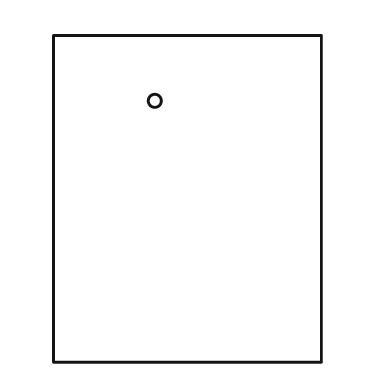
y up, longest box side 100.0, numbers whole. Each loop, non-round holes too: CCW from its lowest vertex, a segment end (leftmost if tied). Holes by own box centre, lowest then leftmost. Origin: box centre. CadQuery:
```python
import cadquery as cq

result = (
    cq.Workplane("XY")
    .moveTo(-41.0, -50.0)
    .lineTo(41.0, -50.0)
    .lineTo(41.0, 50.0)
    .lineTo(-41.0, 50.0)
    .close()
    .moveTo(-10.0, 30.0)
    .circle(2.0)
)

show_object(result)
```